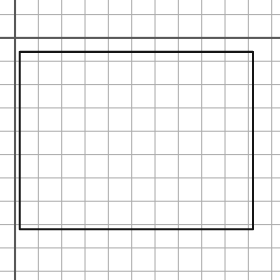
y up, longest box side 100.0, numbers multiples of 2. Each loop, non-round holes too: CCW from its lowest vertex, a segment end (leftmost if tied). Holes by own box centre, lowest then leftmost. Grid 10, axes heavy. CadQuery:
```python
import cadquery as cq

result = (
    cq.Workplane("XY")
    .moveTo(2.0, -82.0)
    .lineTo(102.0, -82.0)
    .lineTo(102.0, -6.0)
    .lineTo(2.0, -6.0)
    .close()
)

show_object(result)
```